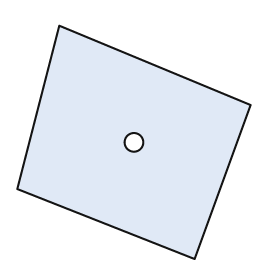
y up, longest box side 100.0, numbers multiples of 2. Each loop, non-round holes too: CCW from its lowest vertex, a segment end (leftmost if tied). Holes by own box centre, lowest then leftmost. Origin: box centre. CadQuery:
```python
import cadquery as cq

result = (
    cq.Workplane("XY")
    .moveTo(26.0, -50.0)
    .lineTo(50.0, 16.0)
    .lineTo(-32.0, 50.0)
    .lineTo(-50.0, -20.0)
    .close()
    .moveTo(0.0, 0.0)
    .circle(4.0)
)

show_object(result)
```